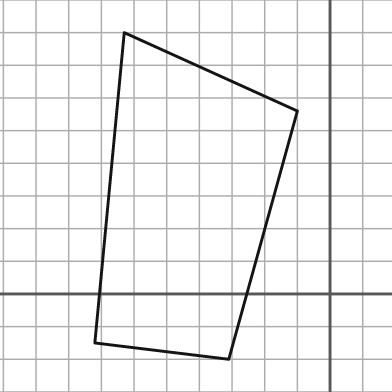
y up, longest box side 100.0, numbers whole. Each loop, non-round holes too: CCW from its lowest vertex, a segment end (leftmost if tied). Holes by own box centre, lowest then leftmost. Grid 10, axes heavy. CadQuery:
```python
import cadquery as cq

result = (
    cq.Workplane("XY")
    .moveTo(-31.0, -20.0)
    .lineTo(-10.0, 56.0)
    .lineTo(-63.0, 80.0)
    .lineTo(-72.0, -15.0)
    .close()
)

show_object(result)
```